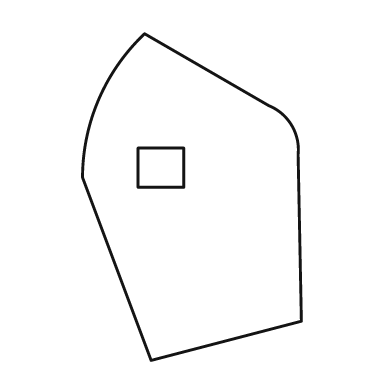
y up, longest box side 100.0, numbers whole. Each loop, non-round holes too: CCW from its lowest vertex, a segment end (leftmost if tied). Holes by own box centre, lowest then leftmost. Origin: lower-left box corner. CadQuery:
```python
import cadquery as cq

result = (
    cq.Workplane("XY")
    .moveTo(21.0, 0.0)
    .lineTo(67.0, 12.0)
    .lineTo(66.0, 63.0)
    .threePointArc((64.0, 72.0), (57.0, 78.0))
    .lineTo(19.0, 100.0)
    .threePointArc((5.0, 80.0), (0.0, 56.0))
    .close()
    .moveTo(17.0, 53.0)
    .lineTo(31.0, 53.0)
    .lineTo(31.0, 65.0)
    .lineTo(17.0, 65.0)
    .close()
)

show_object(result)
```